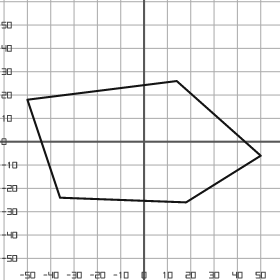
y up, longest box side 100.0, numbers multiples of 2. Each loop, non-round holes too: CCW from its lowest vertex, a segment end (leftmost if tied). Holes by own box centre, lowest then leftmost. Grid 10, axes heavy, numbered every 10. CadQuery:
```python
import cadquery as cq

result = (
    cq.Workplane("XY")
    .moveTo(18.0, -26.0)
    .lineTo(50.0, -6.0)
    .lineTo(14.0, 26.0)
    .lineTo(-50.0, 18.0)
    .lineTo(-36.0, -24.0)
    .close()
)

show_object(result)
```